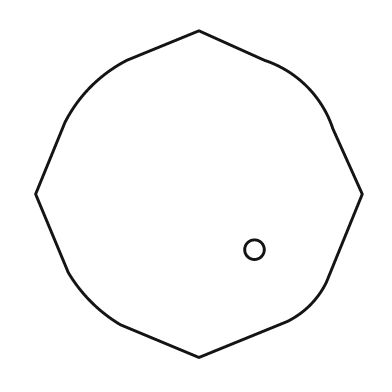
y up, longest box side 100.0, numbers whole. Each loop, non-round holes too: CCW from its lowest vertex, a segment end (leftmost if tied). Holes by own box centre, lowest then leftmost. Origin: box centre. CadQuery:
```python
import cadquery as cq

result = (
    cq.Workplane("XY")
    .moveTo(0.0, -50.0)
    .lineTo(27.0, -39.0)
    .threePointArc((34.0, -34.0), (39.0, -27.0))
    .lineTo(50.0, 0.0)
    .lineTo(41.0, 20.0)
    .threePointArc((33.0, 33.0), (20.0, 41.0))
    .lineTo(0.0, 50.0)
    .lineTo(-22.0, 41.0)
    .threePointArc((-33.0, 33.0), (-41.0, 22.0))
    .lineTo(-50.0, 0.0)
    .lineTo(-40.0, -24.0)
    .threePointArc((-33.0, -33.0), (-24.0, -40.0))
    .close()
    .moveTo(17.0, -17.0)
    .circle(3.0)
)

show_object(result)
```